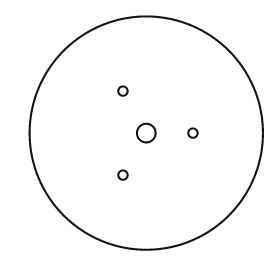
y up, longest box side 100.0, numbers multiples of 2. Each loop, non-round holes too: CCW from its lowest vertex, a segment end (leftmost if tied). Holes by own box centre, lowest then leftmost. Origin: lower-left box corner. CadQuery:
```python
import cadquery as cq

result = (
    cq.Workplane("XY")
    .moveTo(50.0, 50.0)
    .circle(50.0)
    .moveTo(40.0, 32.0)
    .circle(2.0)
    .moveTo(50.0, 50.0)
    .circle(4.0)
    .moveTo(70.0, 50.0)
    .circle(2.0)
    .moveTo(40.0, 68.0)
    .circle(2.0)
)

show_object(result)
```